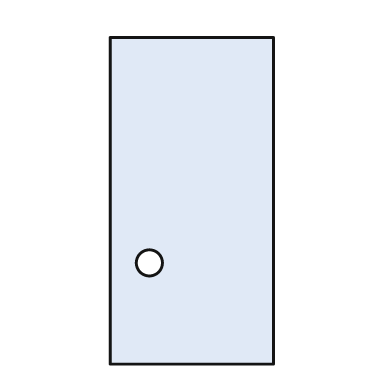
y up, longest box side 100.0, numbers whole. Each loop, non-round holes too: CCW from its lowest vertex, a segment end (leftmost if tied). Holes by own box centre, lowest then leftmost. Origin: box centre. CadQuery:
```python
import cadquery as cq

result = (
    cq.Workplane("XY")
    .moveTo(-25.0, -50.0)
    .lineTo(25.0, -50.0)
    .lineTo(25.0, 50.0)
    .lineTo(-25.0, 50.0)
    .close()
    .moveTo(-13.0, -19.0)
    .circle(4.0)
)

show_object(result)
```